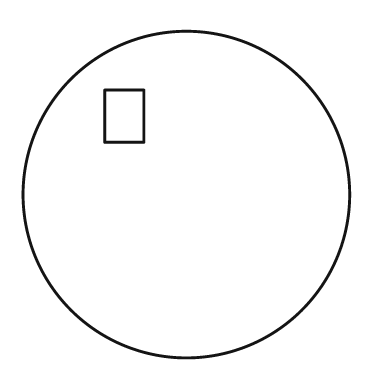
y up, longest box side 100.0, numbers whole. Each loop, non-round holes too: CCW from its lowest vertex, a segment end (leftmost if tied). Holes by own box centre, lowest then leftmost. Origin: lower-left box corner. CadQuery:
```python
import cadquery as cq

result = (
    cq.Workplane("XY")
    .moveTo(50.0, 50.0)
    .circle(50.0)
    .moveTo(25.0, 66.0)
    .lineTo(37.0, 66.0)
    .lineTo(37.0, 82.0)
    .lineTo(25.0, 82.0)
    .close()
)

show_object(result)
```